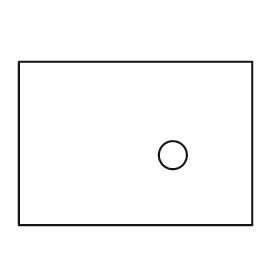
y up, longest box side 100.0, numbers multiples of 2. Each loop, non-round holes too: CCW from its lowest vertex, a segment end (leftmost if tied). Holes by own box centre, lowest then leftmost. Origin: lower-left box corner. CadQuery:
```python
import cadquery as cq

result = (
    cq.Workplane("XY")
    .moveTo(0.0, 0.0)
    .lineTo(100.0, 0.0)
    .lineTo(100.0, 70.0)
    .lineTo(0.0, 70.0)
    .close()
    .moveTo(66.0, 30.0)
    .circle(6.0)
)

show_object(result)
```